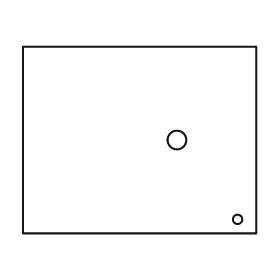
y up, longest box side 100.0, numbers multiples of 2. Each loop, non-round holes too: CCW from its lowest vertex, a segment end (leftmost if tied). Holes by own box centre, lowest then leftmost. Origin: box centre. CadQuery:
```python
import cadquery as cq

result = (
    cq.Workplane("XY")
    .moveTo(-50.0, -40.0)
    .lineTo(50.0, -40.0)
    .lineTo(50.0, 40.0)
    .lineTo(-50.0, 40.0)
    .close()
    .moveTo(42.0, -34.0)
    .circle(2.0)
    .moveTo(16.0, 0.0)
    .circle(4.0)
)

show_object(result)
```